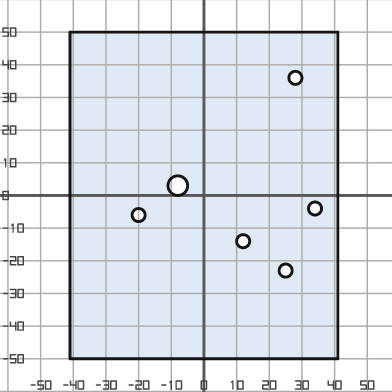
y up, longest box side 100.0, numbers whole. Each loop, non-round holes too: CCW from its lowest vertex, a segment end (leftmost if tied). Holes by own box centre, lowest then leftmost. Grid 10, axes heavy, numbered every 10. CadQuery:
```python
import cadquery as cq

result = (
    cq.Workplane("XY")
    .moveTo(-41.0, -50.0)
    .lineTo(41.0, -50.0)
    .lineTo(41.0, 50.0)
    .lineTo(-41.0, 50.0)
    .close()
    .moveTo(25.0, -23.0)
    .circle(2.0)
    .moveTo(12.0, -14.0)
    .circle(2.0)
    .moveTo(-20.0, -6.0)
    .circle(2.0)
    .moveTo(34.0, -4.0)
    .circle(2.0)
    .moveTo(-8.0, 3.0)
    .circle(3.0)
    .moveTo(28.0, 36.0)
    .circle(2.0)
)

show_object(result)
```